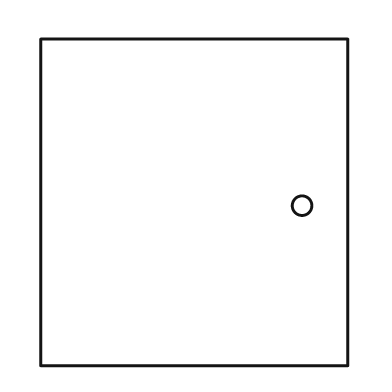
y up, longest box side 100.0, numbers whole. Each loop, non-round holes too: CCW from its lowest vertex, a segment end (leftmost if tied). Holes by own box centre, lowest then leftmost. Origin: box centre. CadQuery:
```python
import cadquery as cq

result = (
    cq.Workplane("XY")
    .moveTo(-47.0, -50.0)
    .lineTo(47.0, -50.0)
    .lineTo(47.0, 50.0)
    .lineTo(-47.0, 50.0)
    .close()
    .moveTo(33.0, -1.0)
    .circle(3.0)
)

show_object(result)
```